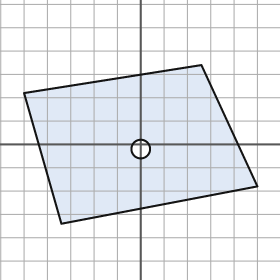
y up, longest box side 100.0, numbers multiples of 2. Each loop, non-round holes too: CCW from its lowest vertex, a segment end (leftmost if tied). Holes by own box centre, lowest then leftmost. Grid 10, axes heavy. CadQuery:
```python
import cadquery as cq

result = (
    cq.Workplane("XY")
    .moveTo(-34.0, -34.0)
    .lineTo(50.0, -18.0)
    .lineTo(26.0, 34.0)
    .lineTo(-50.0, 22.0)
    .close()
    .moveTo(0.0, -2.0)
    .circle(4.0)
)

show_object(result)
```